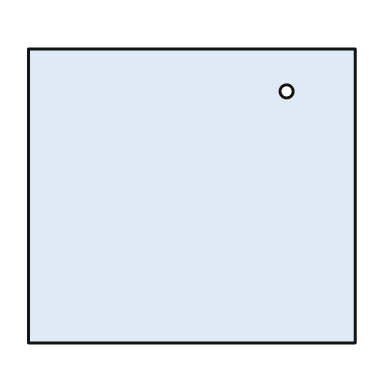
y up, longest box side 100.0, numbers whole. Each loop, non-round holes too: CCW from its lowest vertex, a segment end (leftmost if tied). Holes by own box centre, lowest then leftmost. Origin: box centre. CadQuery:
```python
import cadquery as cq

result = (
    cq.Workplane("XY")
    .moveTo(-50.0, -45.0)
    .lineTo(50.0, -45.0)
    .lineTo(50.0, 45.0)
    .lineTo(-50.0, 45.0)
    .close()
    .moveTo(29.0, 32.0)
    .circle(2.0)
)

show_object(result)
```